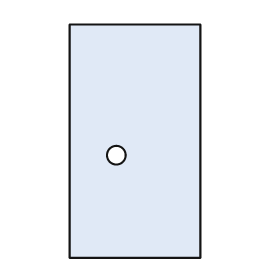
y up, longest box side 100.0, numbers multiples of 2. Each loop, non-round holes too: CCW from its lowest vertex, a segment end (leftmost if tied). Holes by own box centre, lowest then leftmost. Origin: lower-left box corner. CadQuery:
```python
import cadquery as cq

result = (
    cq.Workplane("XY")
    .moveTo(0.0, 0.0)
    .lineTo(56.0, 0.0)
    .lineTo(56.0, 100.0)
    .lineTo(0.0, 100.0)
    .close()
    .moveTo(20.0, 44.0)
    .circle(4.0)
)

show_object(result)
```